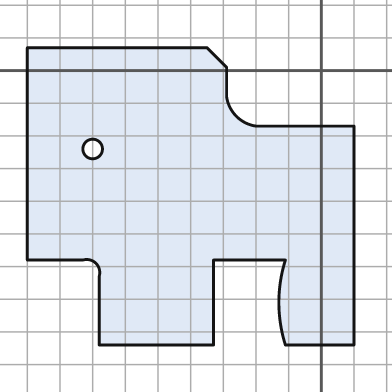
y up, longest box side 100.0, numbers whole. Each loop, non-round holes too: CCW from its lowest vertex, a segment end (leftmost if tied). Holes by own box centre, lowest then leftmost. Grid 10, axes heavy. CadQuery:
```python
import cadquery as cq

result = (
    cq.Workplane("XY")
    .moveTo(-68.0, -84.0)
    .lineTo(-33.0, -84.0)
    .lineTo(-33.0, -58.0)
    .lineTo(-11.0, -58.0)
    .threePointArc((-13.0, -71.0), (-11.0, -84.0))
    .lineTo(10.0, -84.0)
    .lineTo(10.0, -17.0)
    .lineTo(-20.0, -17.0)
    .threePointArc((-26.0, -14.0), (-29.0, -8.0))
    .lineTo(-29.0, 1.0)
    .lineTo(-35.0, 7.0)
    .lineTo(-90.0, 7.0)
    .lineTo(-90.0, -58.0)
    .lineTo(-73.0, -58.0)
    .threePointArc((-69.0, -59.0), (-68.0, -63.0))
    .close()
    .moveTo(-70.0, -24.0)
    .circle(3.0)
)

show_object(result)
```